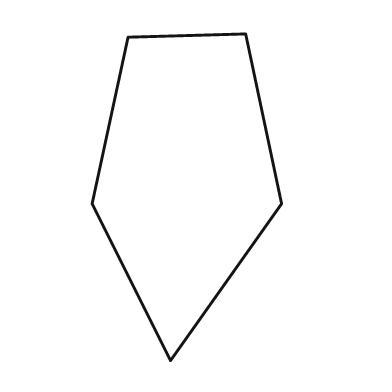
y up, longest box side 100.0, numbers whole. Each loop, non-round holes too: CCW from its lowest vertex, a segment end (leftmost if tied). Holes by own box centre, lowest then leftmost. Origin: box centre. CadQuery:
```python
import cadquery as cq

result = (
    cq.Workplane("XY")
    .moveTo(-5.0, -50.0)
    .lineTo(29.0, -2.0)
    .lineTo(18.0, 50.0)
    .lineTo(-18.0, 49.0)
    .lineTo(-29.0, -2.0)
    .close()
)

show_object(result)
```